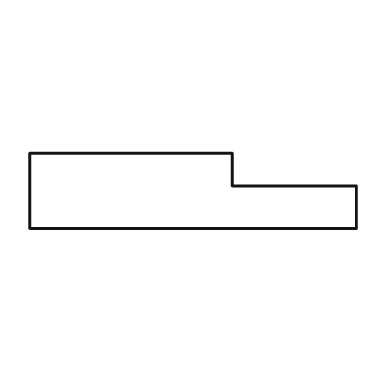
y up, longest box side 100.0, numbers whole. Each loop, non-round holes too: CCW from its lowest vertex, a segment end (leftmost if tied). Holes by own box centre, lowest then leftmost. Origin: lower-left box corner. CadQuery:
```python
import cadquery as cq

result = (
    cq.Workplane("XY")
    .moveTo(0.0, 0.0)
    .lineTo(100.0, 0.0)
    .lineTo(100.0, 13.0)
    .lineTo(62.0, 13.0)
    .lineTo(62.0, 23.0)
    .lineTo(0.0, 23.0)
    .close()
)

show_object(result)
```